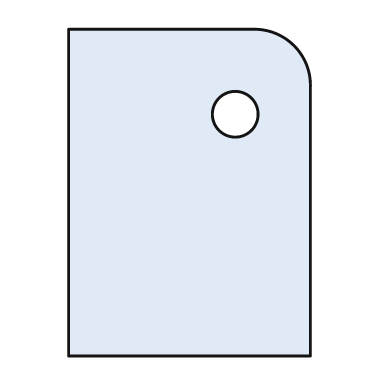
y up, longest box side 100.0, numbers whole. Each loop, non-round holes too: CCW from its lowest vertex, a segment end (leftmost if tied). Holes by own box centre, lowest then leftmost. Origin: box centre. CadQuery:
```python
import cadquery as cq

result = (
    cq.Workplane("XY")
    .moveTo(-37.0, -50.0)
    .lineTo(37.0, -50.0)
    .lineTo(37.0, 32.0)
    .threePointArc((32.0, 45.0), (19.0, 50.0))
    .lineTo(-37.0, 50.0)
    .close()
    .moveTo(14.0, 24.0)
    .circle(7.0)
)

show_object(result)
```